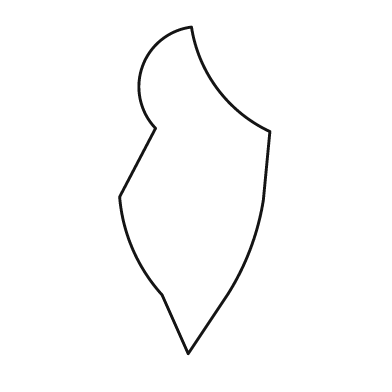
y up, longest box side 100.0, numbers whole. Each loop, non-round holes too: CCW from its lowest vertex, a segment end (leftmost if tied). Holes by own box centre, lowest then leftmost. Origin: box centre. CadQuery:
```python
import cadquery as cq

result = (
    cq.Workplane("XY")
    .moveTo(-2.0, -50.0)
    .lineTo(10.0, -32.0)
    .threePointArc((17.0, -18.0), (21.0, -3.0))
    .lineTo(23.0, 18.0)
    .threePointArc((7.0, 31.0), (-1.0, 50.0))
    .threePointArc((-16.0, 38.0), (-12.0, 19.0))
    .lineTo(-23.0, -2.0)
    .threePointArc((-19.0, -18.0), (-10.0, -32.0))
    .close()
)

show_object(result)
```